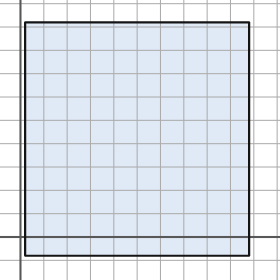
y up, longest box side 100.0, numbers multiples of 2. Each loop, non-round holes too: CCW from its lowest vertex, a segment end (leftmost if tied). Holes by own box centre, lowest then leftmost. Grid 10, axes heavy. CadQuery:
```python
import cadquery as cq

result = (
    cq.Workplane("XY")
    .moveTo(2.0, -8.0)
    .lineTo(98.0, -8.0)
    .lineTo(98.0, 92.0)
    .lineTo(2.0, 92.0)
    .close()
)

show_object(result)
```